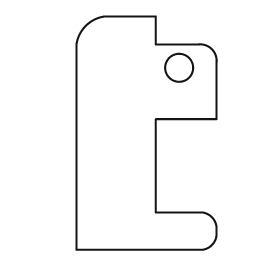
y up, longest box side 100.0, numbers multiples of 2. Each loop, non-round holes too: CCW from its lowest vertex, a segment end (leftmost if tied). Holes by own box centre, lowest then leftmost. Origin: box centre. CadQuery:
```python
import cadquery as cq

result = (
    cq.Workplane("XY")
    .moveTo(-30.0, -50.0)
    .lineTo(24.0, -50.0)
    .threePointArc((28.0, -48.0), (30.0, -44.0))
    .lineTo(30.0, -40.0)
    .threePointArc((28.0, -36.0), (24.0, -34.0))
    .lineTo(4.0, -34.0)
    .lineTo(4.0, 6.0)
    .lineTo(30.0, 6.0)
    .lineTo(30.0, 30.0)
    .threePointArc((28.0, 36.0), (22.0, 38.0))
    .lineTo(4.0, 38.0)
    .lineTo(4.0, 50.0)
    .lineTo(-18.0, 50.0)
    .threePointArc((-26.0, 46.0), (-30.0, 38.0))
    .close()
    .moveTo(14.0, 28.0)
    .circle(6.0)
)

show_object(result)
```